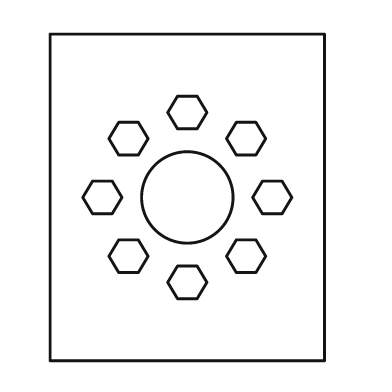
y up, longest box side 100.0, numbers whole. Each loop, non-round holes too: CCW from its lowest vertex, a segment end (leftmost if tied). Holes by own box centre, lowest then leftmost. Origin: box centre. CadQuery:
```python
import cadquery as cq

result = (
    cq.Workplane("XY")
    .moveTo(-42.0, -50.0)
    .lineTo(42.0, -50.0)
    .lineTo(42.0, 50.0)
    .lineTo(-42.0, 50.0)
    .close()
    .moveTo(-3.0, -31.0)
    .lineTo(3.0, -31.0)
    .lineTo(6.0, -26.0)
    .lineTo(3.0, -21.0)
    .lineTo(-3.0, -21.0)
    .lineTo(-6.0, -26.0)
    .close()
    .moveTo(-21.0, -23.0)
    .lineTo(-15.0, -23.0)
    .lineTo(-12.0, -18.0)
    .lineTo(-15.0, -13.0)
    .lineTo(-21.0, -13.0)
    .lineTo(-24.0, -18.0)
    .close()
    .moveTo(15.0, -23.0)
    .lineTo(21.0, -23.0)
    .lineTo(24.0, -18.0)
    .lineTo(21.0, -13.0)
    .lineTo(15.0, -13.0)
    .lineTo(12.0, -18.0)
    .close()
    .moveTo(-29.0, -5.0)
    .lineTo(-23.0, -5.0)
    .lineTo(-20.0, 0.0)
    .lineTo(-23.0, 5.0)
    .lineTo(-29.0, 5.0)
    .lineTo(-32.0, 0.0)
    .close()
    .moveTo(0.0, 0.0)
    .circle(14.0)
    .moveTo(23.0, -5.0)
    .lineTo(29.0, -5.0)
    .lineTo(32.0, 0.0)
    .lineTo(29.0, 5.0)
    .lineTo(23.0, 5.0)
    .lineTo(20.0, 0.0)
    .close()
    .moveTo(-21.0, 13.0)
    .lineTo(-15.0, 13.0)
    .lineTo(-12.0, 18.0)
    .lineTo(-15.0, 23.0)
    .lineTo(-21.0, 23.0)
    .lineTo(-24.0, 18.0)
    .close()
    .moveTo(15.0, 13.0)
    .lineTo(21.0, 13.0)
    .lineTo(24.0, 18.0)
    .lineTo(21.0, 23.0)
    .lineTo(15.0, 23.0)
    .lineTo(12.0, 18.0)
    .close()
    .moveTo(-3.0, 21.0)
    .lineTo(3.0, 21.0)
    .lineTo(6.0, 26.0)
    .lineTo(3.0, 31.0)
    .lineTo(-3.0, 31.0)
    .lineTo(-6.0, 26.0)
    .close()
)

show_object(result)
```